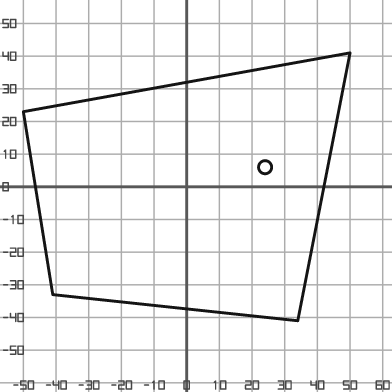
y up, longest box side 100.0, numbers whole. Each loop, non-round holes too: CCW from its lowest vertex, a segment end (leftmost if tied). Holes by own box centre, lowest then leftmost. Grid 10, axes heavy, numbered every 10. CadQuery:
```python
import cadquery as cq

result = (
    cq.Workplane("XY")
    .moveTo(34.0, -41.0)
    .lineTo(50.0, 41.0)
    .lineTo(-50.0, 23.0)
    .lineTo(-41.0, -33.0)
    .close()
    .moveTo(24.0, 6.0)
    .circle(2.0)
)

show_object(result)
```